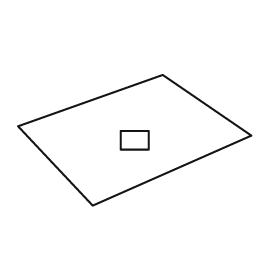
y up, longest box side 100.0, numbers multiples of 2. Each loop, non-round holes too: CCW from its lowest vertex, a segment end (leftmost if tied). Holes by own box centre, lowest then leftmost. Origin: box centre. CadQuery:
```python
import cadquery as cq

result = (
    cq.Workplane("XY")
    .moveTo(-18.0, -28.0)
    .lineTo(50.0, 2.0)
    .lineTo(12.0, 28.0)
    .lineTo(-50.0, 6.0)
    .close()
    .moveTo(-6.0, -4.0)
    .lineTo(6.0, -4.0)
    .lineTo(6.0, 4.0)
    .lineTo(-6.0, 4.0)
    .close()
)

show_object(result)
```